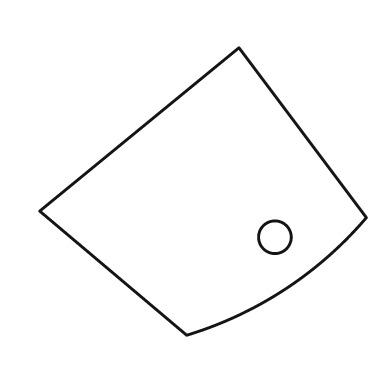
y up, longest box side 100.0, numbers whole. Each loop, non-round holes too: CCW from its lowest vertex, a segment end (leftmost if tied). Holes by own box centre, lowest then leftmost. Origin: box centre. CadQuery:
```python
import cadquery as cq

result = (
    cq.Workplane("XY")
    .moveTo(-5.0, -44.0)
    .threePointArc((25.0, -30.0), (50.0, -8.0))
    .lineTo(11.0, 44.0)
    .lineTo(-50.0, -6.0)
    .close()
    .moveTo(22.0, -14.0)
    .circle(5.0)
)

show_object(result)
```